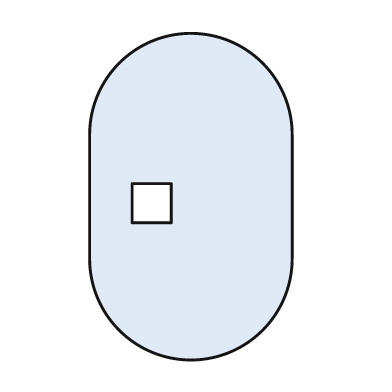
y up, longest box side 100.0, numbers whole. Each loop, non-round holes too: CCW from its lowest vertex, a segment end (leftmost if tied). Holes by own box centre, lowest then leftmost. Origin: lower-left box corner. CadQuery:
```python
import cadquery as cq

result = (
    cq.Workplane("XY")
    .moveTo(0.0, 31.0)
    .threePointArc((31.0, 0.0), (62.0, 31.0))
    .lineTo(62.0, 69.0)
    .threePointArc((31.0, 100.0), (0.0, 69.0))
    .close()
    .moveTo(13.0, 42.0)
    .lineTo(25.0, 42.0)
    .lineTo(25.0, 54.0)
    .lineTo(13.0, 54.0)
    .close()
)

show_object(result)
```